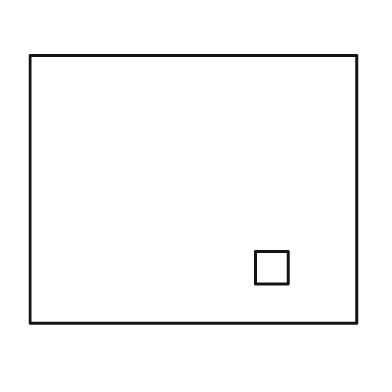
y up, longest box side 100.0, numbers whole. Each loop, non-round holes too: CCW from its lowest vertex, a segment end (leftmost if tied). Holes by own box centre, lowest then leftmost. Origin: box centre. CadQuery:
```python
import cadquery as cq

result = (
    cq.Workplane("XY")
    .moveTo(-50.0, -41.0)
    .lineTo(50.0, -41.0)
    .lineTo(50.0, 41.0)
    .lineTo(-50.0, 41.0)
    .close()
    .moveTo(19.0, -29.0)
    .lineTo(29.0, -29.0)
    .lineTo(29.0, -19.0)
    .lineTo(19.0, -19.0)
    .close()
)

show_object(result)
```